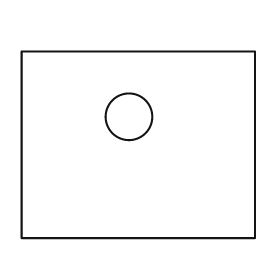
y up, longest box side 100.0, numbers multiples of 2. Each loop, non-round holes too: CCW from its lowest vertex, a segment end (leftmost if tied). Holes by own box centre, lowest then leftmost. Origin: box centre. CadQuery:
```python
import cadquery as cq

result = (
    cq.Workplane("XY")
    .moveTo(-50.0, -40.0)
    .lineTo(50.0, -40.0)
    .lineTo(50.0, 40.0)
    .lineTo(-50.0, 40.0)
    .close()
    .moveTo(-4.0, 12.0)
    .circle(10.0)
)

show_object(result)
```